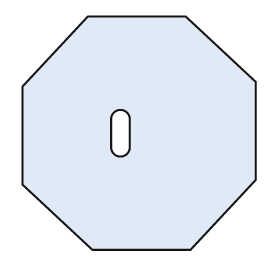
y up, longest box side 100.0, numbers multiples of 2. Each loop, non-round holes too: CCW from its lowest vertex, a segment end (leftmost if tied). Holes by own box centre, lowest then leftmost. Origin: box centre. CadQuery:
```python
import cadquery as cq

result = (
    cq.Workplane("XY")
    .moveTo(-20.0, -50.0)
    .lineTo(22.0, -50.0)
    .lineTo(50.0, -20.0)
    .lineTo(50.0, 22.0)
    .lineTo(20.0, 50.0)
    .lineTo(-22.0, 50.0)
    .lineTo(-50.0, 20.0)
    .lineTo(-50.0, -22.0)
    .close()
    .moveTo(-12.0, -6.0)
    .threePointArc((-8.0, -10.0), (-4.0, -6.0))
    .lineTo(-4.0, 6.0)
    .threePointArc((-8.0, 10.0), (-12.0, 6.0))
    .close()
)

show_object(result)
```